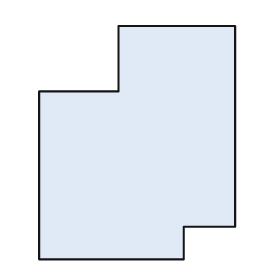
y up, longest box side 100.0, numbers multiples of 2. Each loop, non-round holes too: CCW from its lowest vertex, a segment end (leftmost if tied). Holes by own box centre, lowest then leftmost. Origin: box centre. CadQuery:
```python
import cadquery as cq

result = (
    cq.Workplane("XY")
    .moveTo(-42.0, -50.0)
    .lineTo(20.0, -50.0)
    .lineTo(20.0, -36.0)
    .lineTo(42.0, -36.0)
    .lineTo(42.0, 50.0)
    .lineTo(-8.0, 50.0)
    .lineTo(-8.0, 22.0)
    .lineTo(-42.0, 22.0)
    .close()
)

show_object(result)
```